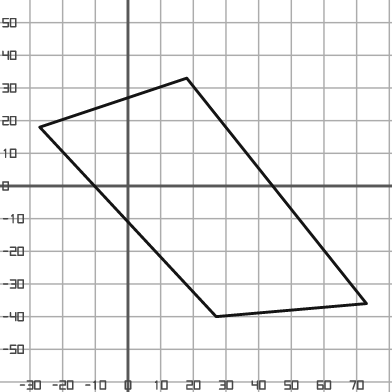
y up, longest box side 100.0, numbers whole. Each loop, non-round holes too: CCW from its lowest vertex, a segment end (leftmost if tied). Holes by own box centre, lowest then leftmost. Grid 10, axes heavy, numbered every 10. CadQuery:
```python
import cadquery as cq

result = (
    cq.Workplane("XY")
    .moveTo(27.0, -40.0)
    .lineTo(73.0, -36.0)
    .lineTo(18.0, 33.0)
    .lineTo(-27.0, 18.0)
    .close()
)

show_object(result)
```